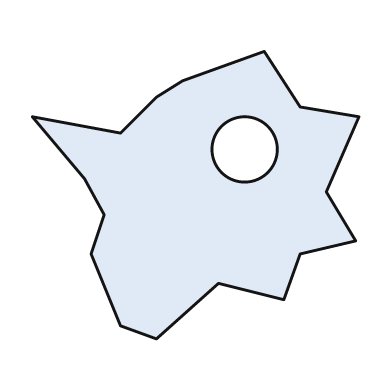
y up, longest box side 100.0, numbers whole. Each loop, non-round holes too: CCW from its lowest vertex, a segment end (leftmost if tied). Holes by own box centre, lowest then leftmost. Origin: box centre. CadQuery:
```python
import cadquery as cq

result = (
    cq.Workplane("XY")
    .moveTo(-12.0, -44.0)
    .lineTo(7.0, -27.0)
    .lineTo(27.0, -32.0)
    .lineTo(32.0, -18.0)
    .lineTo(49.0, -14.0)
    .lineTo(40.0, 1.0)
    .lineTo(50.0, 24.0)
    .lineTo(32.0, 27.0)
    .lineTo(21.0, 44.0)
    .lineTo(-4.0, 35.0)
    .lineTo(-12.0, 30.0)
    .lineTo(-23.0, 19.0)
    .lineTo(-50.0, 24.0)
    .lineTo(-34.0, 5.0)
    .lineTo(-28.0, -6.0)
    .lineTo(-32.0, -18.0)
    .lineTo(-23.0, -40.0)
    .close()
    .moveTo(15.0, 14.0)
    .circle(10.0)
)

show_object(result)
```